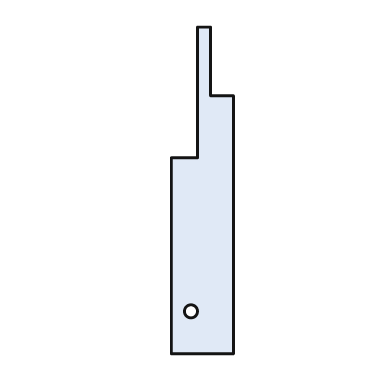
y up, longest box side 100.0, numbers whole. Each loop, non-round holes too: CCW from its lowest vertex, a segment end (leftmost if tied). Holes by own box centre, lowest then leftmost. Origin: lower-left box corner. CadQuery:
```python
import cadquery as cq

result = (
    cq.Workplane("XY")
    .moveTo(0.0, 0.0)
    .lineTo(19.0, 0.0)
    .lineTo(19.0, 79.0)
    .lineTo(12.0, 79.0)
    .lineTo(12.0, 100.0)
    .lineTo(8.0, 100.0)
    .lineTo(8.0, 60.0)
    .lineTo(0.0, 60.0)
    .close()
    .moveTo(6.0, 13.0)
    .circle(2.0)
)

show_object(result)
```